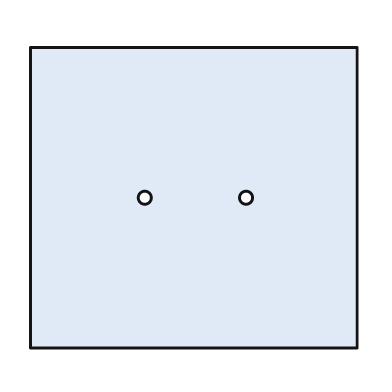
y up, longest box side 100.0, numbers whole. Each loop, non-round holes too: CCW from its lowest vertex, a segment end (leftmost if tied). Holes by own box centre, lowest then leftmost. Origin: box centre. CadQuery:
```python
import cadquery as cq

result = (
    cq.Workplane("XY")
    .moveTo(-50.0, -46.0)
    .lineTo(50.0, -46.0)
    .lineTo(50.0, 46.0)
    .lineTo(-50.0, 46.0)
    .close()
    .moveTo(-15.0, 0.0)
    .circle(2.0)
    .moveTo(16.0, 0.0)
    .circle(2.0)
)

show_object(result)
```